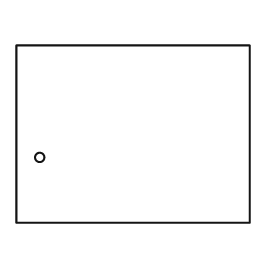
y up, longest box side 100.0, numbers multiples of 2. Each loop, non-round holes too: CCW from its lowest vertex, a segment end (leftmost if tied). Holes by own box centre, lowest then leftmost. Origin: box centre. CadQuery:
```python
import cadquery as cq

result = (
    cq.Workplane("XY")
    .moveTo(-50.0, -38.0)
    .lineTo(50.0, -38.0)
    .lineTo(50.0, 38.0)
    .lineTo(-50.0, 38.0)
    .close()
    .moveTo(-40.0, -10.0)
    .circle(2.0)
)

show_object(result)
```